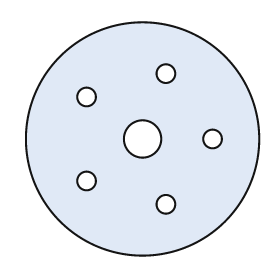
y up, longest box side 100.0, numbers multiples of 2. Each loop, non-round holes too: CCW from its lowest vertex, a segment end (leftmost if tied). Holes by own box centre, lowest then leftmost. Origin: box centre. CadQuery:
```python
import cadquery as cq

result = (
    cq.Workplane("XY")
    .moveTo(0.0, 0.0)
    .circle(50.0)
    .moveTo(10.0, -28.0)
    .circle(4.0)
    .moveTo(-24.0, -18.0)
    .circle(4.0)
    .moveTo(0.0, 0.0)
    .circle(8.0)
    .moveTo(30.0, 0.0)
    .circle(4.0)
    .moveTo(-24.0, 18.0)
    .circle(4.0)
    .moveTo(10.0, 28.0)
    .circle(4.0)
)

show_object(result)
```